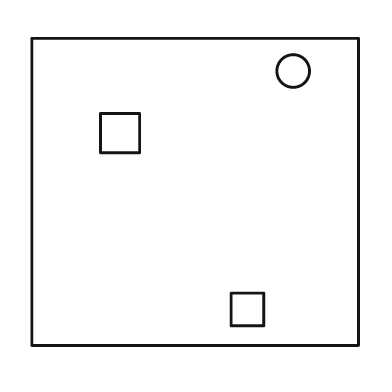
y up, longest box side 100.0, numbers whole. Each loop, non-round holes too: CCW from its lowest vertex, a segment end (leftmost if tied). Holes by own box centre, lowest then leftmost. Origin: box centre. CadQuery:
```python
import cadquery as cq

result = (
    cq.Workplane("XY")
    .moveTo(-50.0, -47.0)
    .lineTo(50.0, -47.0)
    .lineTo(50.0, 47.0)
    .lineTo(-50.0, 47.0)
    .close()
    .moveTo(11.0, -41.0)
    .lineTo(21.0, -41.0)
    .lineTo(21.0, -31.0)
    .lineTo(11.0, -31.0)
    .close()
    .moveTo(-29.0, 12.0)
    .lineTo(-17.0, 12.0)
    .lineTo(-17.0, 24.0)
    .lineTo(-29.0, 24.0)
    .close()
    .moveTo(30.0, 37.0)
    .circle(5.0)
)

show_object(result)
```